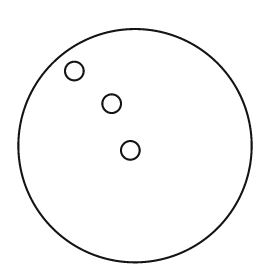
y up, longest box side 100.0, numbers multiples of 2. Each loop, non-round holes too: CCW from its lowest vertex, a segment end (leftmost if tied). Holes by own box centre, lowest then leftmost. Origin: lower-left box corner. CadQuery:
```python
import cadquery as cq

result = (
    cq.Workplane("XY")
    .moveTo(50.0, 50.0)
    .circle(50.0)
    .moveTo(48.0, 48.0)
    .circle(4.0)
    .moveTo(40.0, 68.0)
    .circle(4.0)
    .moveTo(24.0, 82.0)
    .circle(4.0)
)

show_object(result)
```